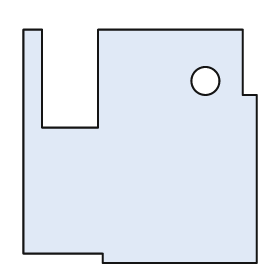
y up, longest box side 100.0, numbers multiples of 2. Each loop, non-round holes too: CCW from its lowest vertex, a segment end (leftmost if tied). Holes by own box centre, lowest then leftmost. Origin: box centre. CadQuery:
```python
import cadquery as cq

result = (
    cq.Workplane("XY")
    .moveTo(-16.0, -50.0)
    .lineTo(50.0, -50.0)
    .lineTo(50.0, 22.0)
    .lineTo(44.0, 22.0)
    .lineTo(44.0, 50.0)
    .lineTo(-18.0, 50.0)
    .lineTo(-18.0, 8.0)
    .lineTo(-42.0, 8.0)
    .lineTo(-42.0, 50.0)
    .lineTo(-50.0, 50.0)
    .lineTo(-50.0, -46.0)
    .lineTo(-16.0, -46.0)
    .close()
    .moveTo(28.0, 28.0)
    .circle(6.0)
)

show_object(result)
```